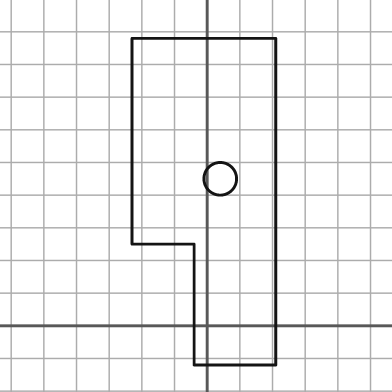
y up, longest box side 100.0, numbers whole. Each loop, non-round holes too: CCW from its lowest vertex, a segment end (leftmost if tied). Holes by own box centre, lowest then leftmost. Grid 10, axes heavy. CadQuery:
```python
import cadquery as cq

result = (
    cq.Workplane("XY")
    .moveTo(-4.0, -12.0)
    .lineTo(21.0, -12.0)
    .lineTo(21.0, 88.0)
    .lineTo(-23.0, 88.0)
    .lineTo(-23.0, 25.0)
    .lineTo(-4.0, 25.0)
    .close()
    .moveTo(4.0, 45.0)
    .circle(5.0)
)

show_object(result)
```